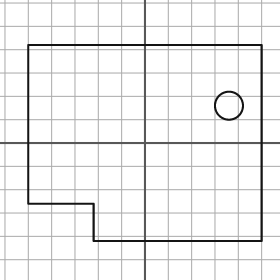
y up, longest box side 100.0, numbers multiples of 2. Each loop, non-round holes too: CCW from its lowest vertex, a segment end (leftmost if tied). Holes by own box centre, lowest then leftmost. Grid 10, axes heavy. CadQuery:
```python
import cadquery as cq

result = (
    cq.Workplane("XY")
    .moveTo(-22.0, -42.0)
    .lineTo(50.0, -42.0)
    .lineTo(50.0, 42.0)
    .lineTo(-50.0, 42.0)
    .lineTo(-50.0, -26.0)
    .lineTo(-22.0, -26.0)
    .close()
    .moveTo(36.0, 16.0)
    .circle(6.0)
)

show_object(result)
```